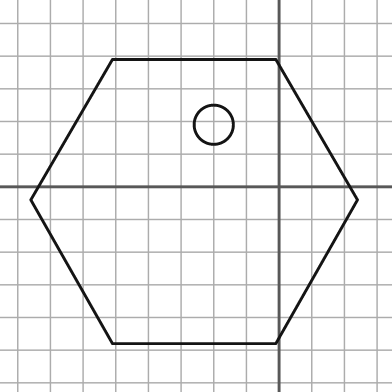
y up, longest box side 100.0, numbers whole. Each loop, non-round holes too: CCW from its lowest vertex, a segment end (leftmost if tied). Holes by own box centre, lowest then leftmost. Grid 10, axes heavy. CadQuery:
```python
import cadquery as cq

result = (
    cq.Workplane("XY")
    .moveTo(-51.0, -48.0)
    .lineTo(-1.0, -48.0)
    .lineTo(24.0, -4.0)
    .lineTo(-1.0, 39.0)
    .lineTo(-51.0, 39.0)
    .lineTo(-76.0, -4.0)
    .close()
    .moveTo(-20.0, 19.0)
    .circle(6.0)
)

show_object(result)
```